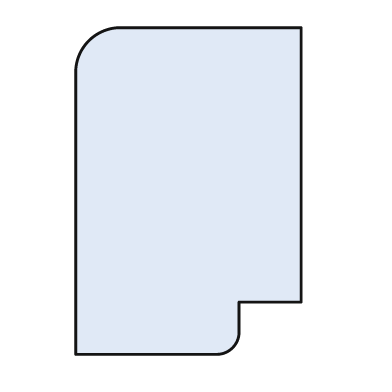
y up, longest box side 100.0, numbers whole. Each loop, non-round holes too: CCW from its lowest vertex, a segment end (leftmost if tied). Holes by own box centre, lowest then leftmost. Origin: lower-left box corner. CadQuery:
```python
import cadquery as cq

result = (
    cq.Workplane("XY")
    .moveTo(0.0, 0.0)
    .lineTo(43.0, 0.0)
    .threePointArc((48.0, 2.0), (50.0, 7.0))
    .lineTo(50.0, 16.0)
    .lineTo(69.0, 16.0)
    .lineTo(69.0, 100.0)
    .lineTo(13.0, 100.0)
    .threePointArc((4.0, 96.0), (0.0, 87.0))
    .close()
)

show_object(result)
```